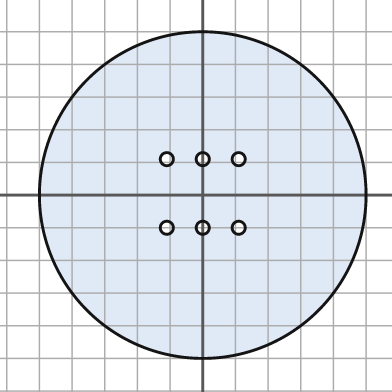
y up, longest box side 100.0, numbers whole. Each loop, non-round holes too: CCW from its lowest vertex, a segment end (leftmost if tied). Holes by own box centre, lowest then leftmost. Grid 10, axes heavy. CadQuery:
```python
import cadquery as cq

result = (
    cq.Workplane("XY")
    .moveTo(0.0, 0.0)
    .circle(50.0)
    .moveTo(-11.0, -10.0)
    .circle(2.0)
    .moveTo(0.0, -10.0)
    .circle(2.0)
    .moveTo(11.0, -10.0)
    .circle(2.0)
    .moveTo(-11.0, 11.0)
    .circle(2.0)
    .moveTo(0.0, 11.0)
    .circle(2.0)
    .moveTo(11.0, 11.0)
    .circle(2.0)
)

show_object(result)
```